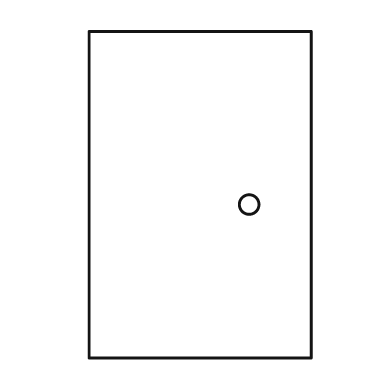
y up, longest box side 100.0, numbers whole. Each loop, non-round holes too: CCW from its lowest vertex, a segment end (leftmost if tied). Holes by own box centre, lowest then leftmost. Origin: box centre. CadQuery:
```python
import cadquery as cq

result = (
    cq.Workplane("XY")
    .moveTo(-34.0, -50.0)
    .lineTo(34.0, -50.0)
    .lineTo(34.0, 50.0)
    .lineTo(-34.0, 50.0)
    .close()
    .moveTo(15.0, -3.0)
    .circle(3.0)
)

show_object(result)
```